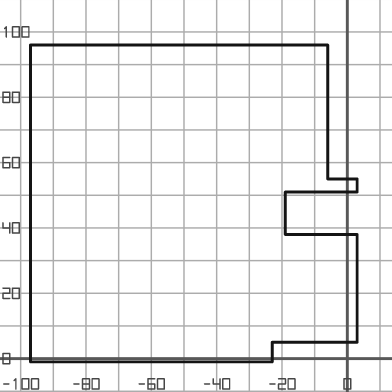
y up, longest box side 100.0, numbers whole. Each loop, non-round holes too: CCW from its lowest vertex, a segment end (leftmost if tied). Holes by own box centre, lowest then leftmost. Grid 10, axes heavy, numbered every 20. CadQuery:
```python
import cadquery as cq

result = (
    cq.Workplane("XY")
    .moveTo(-97.0, -1.0)
    .lineTo(-23.0, -1.0)
    .lineTo(-23.0, 5.0)
    .lineTo(3.0, 5.0)
    .lineTo(3.0, 38.0)
    .lineTo(-19.0, 38.0)
    .lineTo(-19.0, 51.0)
    .lineTo(3.0, 51.0)
    .lineTo(3.0, 55.0)
    .lineTo(-6.0, 55.0)
    .lineTo(-6.0, 96.0)
    .lineTo(-97.0, 96.0)
    .close()
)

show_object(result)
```